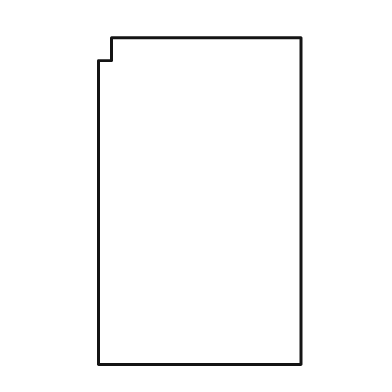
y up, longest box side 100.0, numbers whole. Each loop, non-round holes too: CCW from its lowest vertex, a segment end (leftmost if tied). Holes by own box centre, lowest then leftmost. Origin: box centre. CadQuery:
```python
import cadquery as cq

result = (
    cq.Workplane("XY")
    .moveTo(-31.0, -50.0)
    .lineTo(31.0, -50.0)
    .lineTo(31.0, 50.0)
    .lineTo(-27.0, 50.0)
    .lineTo(-27.0, 43.0)
    .lineTo(-31.0, 43.0)
    .close()
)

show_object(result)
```